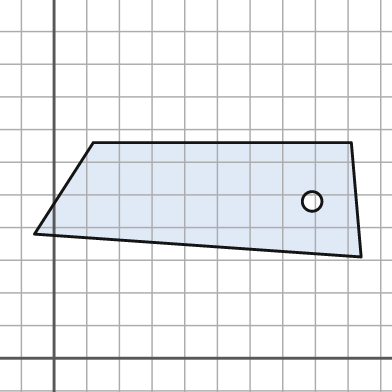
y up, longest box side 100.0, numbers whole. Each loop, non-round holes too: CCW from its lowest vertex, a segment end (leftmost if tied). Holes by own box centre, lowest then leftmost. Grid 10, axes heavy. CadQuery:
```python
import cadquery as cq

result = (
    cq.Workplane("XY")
    .moveTo(94.0, 31.0)
    .lineTo(91.0, 66.0)
    .lineTo(12.0, 66.0)
    .lineTo(-6.0, 38.0)
    .close()
    .moveTo(79.0, 48.0)
    .circle(3.0)
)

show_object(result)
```